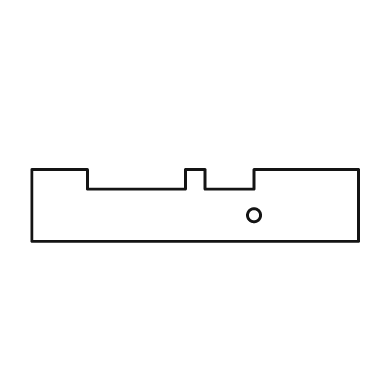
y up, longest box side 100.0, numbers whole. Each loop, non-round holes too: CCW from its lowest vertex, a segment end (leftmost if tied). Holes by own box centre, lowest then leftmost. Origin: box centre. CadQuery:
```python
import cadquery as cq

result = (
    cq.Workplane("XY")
    .moveTo(-50.0, -11.0)
    .lineTo(50.0, -11.0)
    .lineTo(50.0, 11.0)
    .lineTo(18.0, 11.0)
    .lineTo(18.0, 5.0)
    .lineTo(3.0, 5.0)
    .lineTo(3.0, 11.0)
    .lineTo(-3.0, 11.0)
    .lineTo(-3.0, 5.0)
    .lineTo(-33.0, 5.0)
    .lineTo(-33.0, 11.0)
    .lineTo(-50.0, 11.0)
    .close()
    .moveTo(18.0, -3.0)
    .circle(2.0)
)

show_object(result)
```